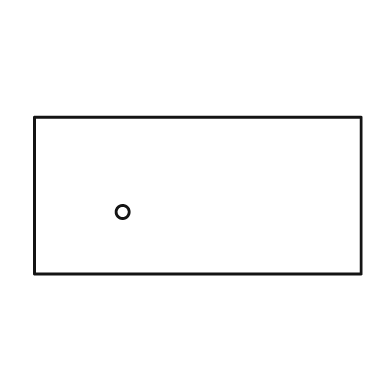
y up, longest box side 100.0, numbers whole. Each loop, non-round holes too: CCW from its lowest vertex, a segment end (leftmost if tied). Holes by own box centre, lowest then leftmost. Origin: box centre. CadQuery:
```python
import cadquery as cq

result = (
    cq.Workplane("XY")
    .moveTo(-50.0, -24.0)
    .lineTo(50.0, -24.0)
    .lineTo(50.0, 24.0)
    .lineTo(-50.0, 24.0)
    .close()
    .moveTo(-23.0, -5.0)
    .circle(2.0)
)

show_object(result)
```